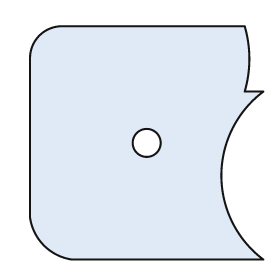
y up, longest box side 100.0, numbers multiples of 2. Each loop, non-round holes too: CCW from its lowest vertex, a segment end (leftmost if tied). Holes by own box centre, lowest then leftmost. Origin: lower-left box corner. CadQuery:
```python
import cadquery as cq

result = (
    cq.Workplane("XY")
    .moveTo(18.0, 0.0)
    .lineTo(100.0, 0.0)
    .threePointArc((82.0, 36.0), (100.0, 72.0))
    .lineTo(92.0, 72.0)
    .threePointArc((94.0, 86.0), (92.0, 100.0))
    .lineTo(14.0, 100.0)
    .threePointArc((4.0, 96.0), (0.0, 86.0))
    .lineTo(0.0, 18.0)
    .threePointArc((6.0, 6.0), (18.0, 0.0))
    .close()
    .moveTo(50.0, 50.0)
    .circle(6.0)
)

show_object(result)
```